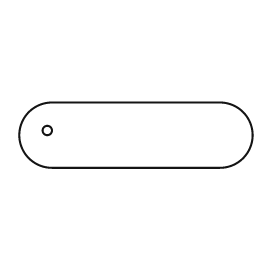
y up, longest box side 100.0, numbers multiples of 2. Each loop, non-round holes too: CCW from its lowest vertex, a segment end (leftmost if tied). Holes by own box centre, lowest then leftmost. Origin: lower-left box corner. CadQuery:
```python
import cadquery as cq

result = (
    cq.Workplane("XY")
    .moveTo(14.0, 0.0)
    .lineTo(86.0, 0.0)
    .threePointArc((100.0, 14.0), (86.0, 28.0))
    .lineTo(14.0, 28.0)
    .threePointArc((0.0, 14.0), (14.0, 0.0))
    .close()
    .moveTo(12.0, 16.0)
    .circle(2.0)
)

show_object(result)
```